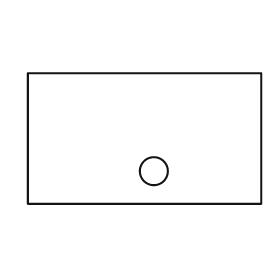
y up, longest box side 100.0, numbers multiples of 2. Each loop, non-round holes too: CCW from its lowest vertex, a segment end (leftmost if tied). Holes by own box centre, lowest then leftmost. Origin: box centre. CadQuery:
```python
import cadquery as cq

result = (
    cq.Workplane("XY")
    .moveTo(-50.0, -28.0)
    .lineTo(50.0, -28.0)
    .lineTo(50.0, 28.0)
    .lineTo(-50.0, 28.0)
    .close()
    .moveTo(4.0, -14.0)
    .circle(6.0)
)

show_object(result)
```